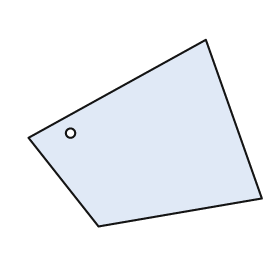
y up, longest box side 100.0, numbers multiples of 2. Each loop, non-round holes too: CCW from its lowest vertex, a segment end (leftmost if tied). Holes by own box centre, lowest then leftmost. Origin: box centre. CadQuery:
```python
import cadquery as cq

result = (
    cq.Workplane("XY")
    .moveTo(-20.0, -40.0)
    .lineTo(50.0, -28.0)
    .lineTo(26.0, 40.0)
    .lineTo(-50.0, -2.0)
    .close()
    .moveTo(-32.0, 0.0)
    .circle(2.0)
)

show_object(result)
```